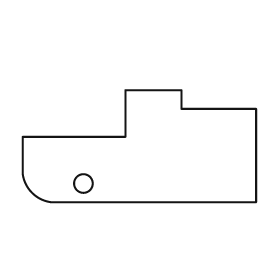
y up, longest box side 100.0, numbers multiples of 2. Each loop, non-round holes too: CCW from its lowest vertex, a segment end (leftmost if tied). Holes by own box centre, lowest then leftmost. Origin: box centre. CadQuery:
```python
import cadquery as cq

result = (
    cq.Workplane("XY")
    .moveTo(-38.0, -24.0)
    .lineTo(50.0, -24.0)
    .lineTo(50.0, 16.0)
    .lineTo(18.0, 16.0)
    .lineTo(18.0, 24.0)
    .lineTo(-6.0, 24.0)
    .lineTo(-6.0, 4.0)
    .lineTo(-50.0, 4.0)
    .lineTo(-50.0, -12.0)
    .threePointArc((-46.0, -20.0), (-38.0, -24.0))
    .close()
    .moveTo(-24.0, -16.0)
    .circle(4.0)
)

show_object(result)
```